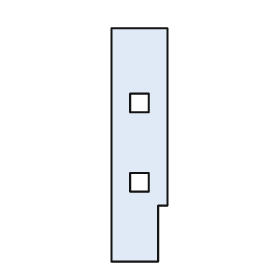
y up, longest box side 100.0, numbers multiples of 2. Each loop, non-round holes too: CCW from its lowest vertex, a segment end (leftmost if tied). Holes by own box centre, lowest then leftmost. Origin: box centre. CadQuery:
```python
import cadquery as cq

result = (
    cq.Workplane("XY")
    .moveTo(-12.0, -50.0)
    .lineTo(8.0, -50.0)
    .lineTo(8.0, -26.0)
    .lineTo(12.0, -26.0)
    .lineTo(12.0, 50.0)
    .lineTo(-12.0, 50.0)
    .close()
    .moveTo(-4.0, -20.0)
    .lineTo(4.0, -20.0)
    .lineTo(4.0, -12.0)
    .lineTo(-4.0, -12.0)
    .close()
    .moveTo(-4.0, 14.0)
    .lineTo(4.0, 14.0)
    .lineTo(4.0, 22.0)
    .lineTo(-4.0, 22.0)
    .close()
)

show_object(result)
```